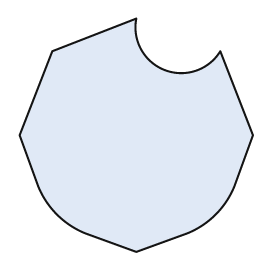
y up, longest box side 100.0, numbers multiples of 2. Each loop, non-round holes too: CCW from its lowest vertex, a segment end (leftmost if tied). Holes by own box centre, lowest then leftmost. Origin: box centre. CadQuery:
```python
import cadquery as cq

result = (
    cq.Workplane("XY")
    .moveTo(0.0, -50.0)
    .lineTo(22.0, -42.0)
    .threePointArc((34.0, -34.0), (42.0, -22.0))
    .lineTo(50.0, 0.0)
    .lineTo(36.0, 36.0)
    .threePointArc((12.0, 28.0), (0.0, 50.0))
    .lineTo(-36.0, 36.0)
    .lineTo(-50.0, 0.0)
    .lineTo(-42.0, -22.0)
    .threePointArc((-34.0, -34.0), (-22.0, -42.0))
    .close()
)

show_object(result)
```